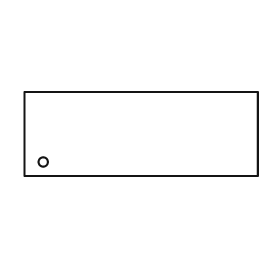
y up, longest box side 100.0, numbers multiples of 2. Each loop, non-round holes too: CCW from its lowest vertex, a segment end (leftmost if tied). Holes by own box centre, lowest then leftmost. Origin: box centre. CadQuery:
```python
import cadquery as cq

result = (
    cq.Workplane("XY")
    .moveTo(-50.0, -18.0)
    .lineTo(50.0, -18.0)
    .lineTo(50.0, 18.0)
    .lineTo(-50.0, 18.0)
    .close()
    .moveTo(-42.0, -12.0)
    .circle(2.0)
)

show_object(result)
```